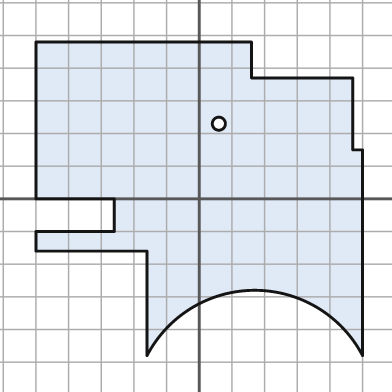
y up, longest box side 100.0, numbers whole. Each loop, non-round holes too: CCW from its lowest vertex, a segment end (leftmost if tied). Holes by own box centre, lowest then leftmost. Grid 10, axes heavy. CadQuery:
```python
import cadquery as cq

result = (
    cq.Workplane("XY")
    .moveTo(-16.0, -48.0)
    .threePointArc((17.0, -28.0), (50.0, -48.0))
    .lineTo(50.0, 15.0)
    .lineTo(47.0, 15.0)
    .lineTo(47.0, 37.0)
    .lineTo(16.0, 37.0)
    .lineTo(16.0, 48.0)
    .lineTo(-50.0, 48.0)
    .lineTo(-50.0, 0.0)
    .lineTo(-26.0, 0.0)
    .lineTo(-26.0, -10.0)
    .lineTo(-50.0, -10.0)
    .lineTo(-50.0, -16.0)
    .lineTo(-16.0, -16.0)
    .close()
    .moveTo(6.0, 23.0)
    .circle(2.0)
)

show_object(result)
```